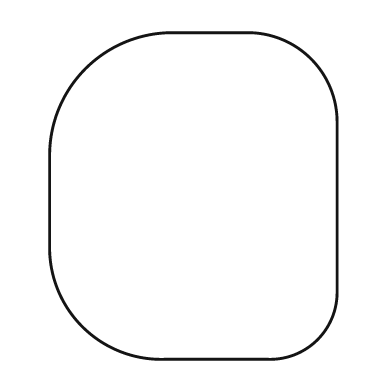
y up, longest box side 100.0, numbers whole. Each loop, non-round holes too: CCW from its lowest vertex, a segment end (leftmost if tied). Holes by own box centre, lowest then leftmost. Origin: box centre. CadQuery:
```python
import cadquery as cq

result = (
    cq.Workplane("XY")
    .moveTo(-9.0, -50.0)
    .lineTo(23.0, -50.0)
    .threePointArc((38.0, -44.0), (44.0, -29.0))
    .lineTo(44.0, 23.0)
    .threePointArc((36.0, 42.0), (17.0, 50.0))
    .lineTo(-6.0, 50.0)
    .threePointArc((-33.0, 39.0), (-44.0, 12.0))
    .lineTo(-44.0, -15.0)
    .threePointArc((-34.0, -40.0), (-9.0, -50.0))
    .close()
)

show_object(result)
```